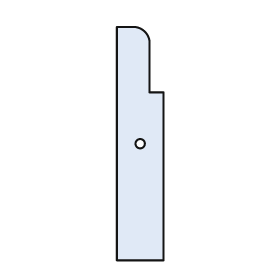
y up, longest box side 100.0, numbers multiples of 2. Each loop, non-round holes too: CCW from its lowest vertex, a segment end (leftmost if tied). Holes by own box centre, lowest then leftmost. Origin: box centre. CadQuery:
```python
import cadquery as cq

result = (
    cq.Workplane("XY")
    .moveTo(-10.0, -50.0)
    .lineTo(10.0, -50.0)
    .lineTo(10.0, 22.0)
    .lineTo(4.0, 22.0)
    .lineTo(4.0, 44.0)
    .threePointArc((2.0, 48.0), (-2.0, 50.0))
    .lineTo(-10.0, 50.0)
    .close()
    .moveTo(0.0, 0.0)
    .circle(2.0)
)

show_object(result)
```